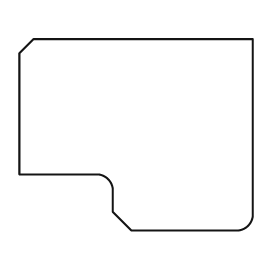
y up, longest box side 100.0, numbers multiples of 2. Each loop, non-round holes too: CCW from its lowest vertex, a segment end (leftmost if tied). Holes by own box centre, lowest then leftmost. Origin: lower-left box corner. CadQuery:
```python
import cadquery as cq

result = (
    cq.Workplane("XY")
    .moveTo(48.0, 0.0)
    .lineTo(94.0, 0.0)
    .threePointArc((98.0, 2.0), (100.0, 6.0))
    .lineTo(100.0, 82.0)
    .lineTo(6.0, 82.0)
    .lineTo(0.0, 76.0)
    .lineTo(0.0, 24.0)
    .lineTo(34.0, 24.0)
    .threePointArc((38.0, 22.0), (40.0, 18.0))
    .lineTo(40.0, 8.0)
    .close()
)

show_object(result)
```